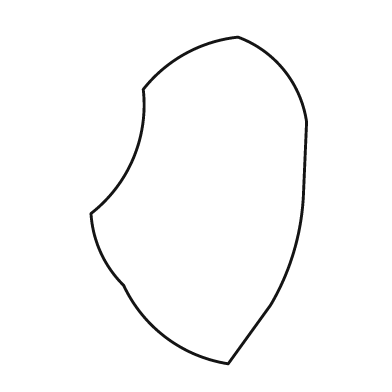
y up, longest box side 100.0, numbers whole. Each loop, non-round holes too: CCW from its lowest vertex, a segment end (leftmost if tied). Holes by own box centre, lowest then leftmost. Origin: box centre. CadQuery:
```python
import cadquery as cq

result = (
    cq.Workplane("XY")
    .moveTo(9.0, -50.0)
    .lineTo(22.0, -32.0)
    .threePointArc((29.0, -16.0), (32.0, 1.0))
    .lineTo(33.0, 24.0)
    .threePointArc((26.0, 40.0), (12.0, 50.0))
    .threePointArc((-4.0, 45.0), (-17.0, 34.0))
    .threePointArc((-20.0, 13.0), (-33.0, -4.0))
    .threePointArc((-30.0, -16.0), (-23.0, -26.0))
    .threePointArc((-10.0, -42.0), (9.0, -50.0))
    .close()
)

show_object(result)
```